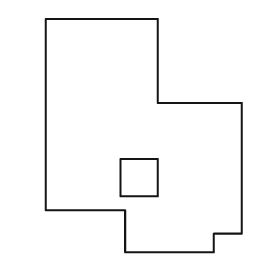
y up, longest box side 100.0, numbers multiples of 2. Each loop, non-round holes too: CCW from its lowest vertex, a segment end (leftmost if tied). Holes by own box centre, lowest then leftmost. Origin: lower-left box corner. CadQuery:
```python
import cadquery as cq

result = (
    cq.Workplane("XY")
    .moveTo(34.0, 0.0)
    .lineTo(72.0, 0.0)
    .lineTo(72.0, 8.0)
    .lineTo(84.0, 8.0)
    .lineTo(84.0, 64.0)
    .lineTo(48.0, 64.0)
    .lineTo(48.0, 100.0)
    .lineTo(0.0, 100.0)
    .lineTo(0.0, 18.0)
    .lineTo(34.0, 18.0)
    .close()
    .moveTo(32.0, 24.0)
    .lineTo(48.0, 24.0)
    .lineTo(48.0, 40.0)
    .lineTo(32.0, 40.0)
    .close()
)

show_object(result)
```